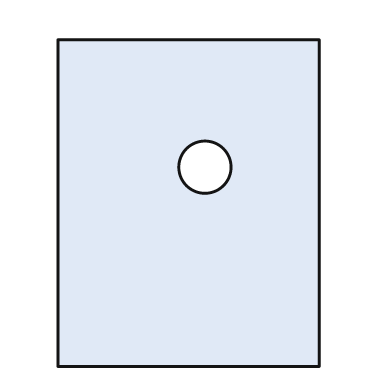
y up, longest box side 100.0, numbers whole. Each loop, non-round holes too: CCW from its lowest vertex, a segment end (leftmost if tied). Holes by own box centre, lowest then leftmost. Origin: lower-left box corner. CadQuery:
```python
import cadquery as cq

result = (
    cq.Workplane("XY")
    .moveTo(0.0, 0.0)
    .lineTo(80.0, 0.0)
    .lineTo(80.0, 100.0)
    .lineTo(0.0, 100.0)
    .close()
    .moveTo(45.0, 61.0)
    .circle(8.0)
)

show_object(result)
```